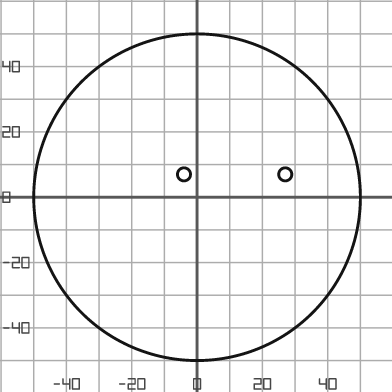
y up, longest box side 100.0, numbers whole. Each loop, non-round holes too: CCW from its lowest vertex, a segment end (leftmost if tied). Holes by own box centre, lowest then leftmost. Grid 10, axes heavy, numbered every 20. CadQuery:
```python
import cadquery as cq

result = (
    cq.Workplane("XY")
    .moveTo(0.0, 0.0)
    .circle(50.0)
    .moveTo(-4.0, 7.0)
    .circle(2.0)
    .moveTo(27.0, 7.0)
    .circle(2.0)
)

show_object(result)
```